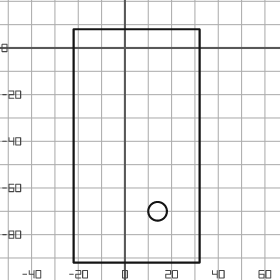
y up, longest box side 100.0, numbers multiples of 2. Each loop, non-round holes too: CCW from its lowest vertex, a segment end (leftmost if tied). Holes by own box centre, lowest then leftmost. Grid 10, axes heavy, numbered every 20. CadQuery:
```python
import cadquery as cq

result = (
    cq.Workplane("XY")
    .moveTo(-22.0, -92.0)
    .lineTo(32.0, -92.0)
    .lineTo(32.0, 8.0)
    .lineTo(-22.0, 8.0)
    .close()
    .moveTo(14.0, -70.0)
    .circle(4.0)
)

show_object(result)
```